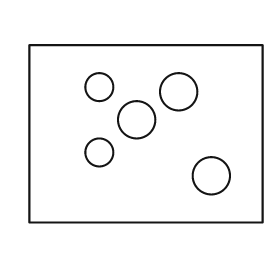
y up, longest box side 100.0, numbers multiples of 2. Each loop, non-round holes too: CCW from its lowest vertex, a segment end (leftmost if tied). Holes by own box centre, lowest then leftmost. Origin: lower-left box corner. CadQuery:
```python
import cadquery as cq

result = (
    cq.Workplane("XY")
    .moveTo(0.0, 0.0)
    .lineTo(100.0, 0.0)
    .lineTo(100.0, 76.0)
    .lineTo(0.0, 76.0)
    .close()
    .moveTo(78.0, 20.0)
    .circle(8.0)
    .moveTo(30.0, 30.0)
    .circle(6.0)
    .moveTo(46.0, 44.0)
    .circle(8.0)
    .moveTo(64.0, 56.0)
    .circle(8.0)
    .moveTo(30.0, 58.0)
    .circle(6.0)
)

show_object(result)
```